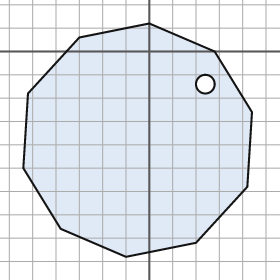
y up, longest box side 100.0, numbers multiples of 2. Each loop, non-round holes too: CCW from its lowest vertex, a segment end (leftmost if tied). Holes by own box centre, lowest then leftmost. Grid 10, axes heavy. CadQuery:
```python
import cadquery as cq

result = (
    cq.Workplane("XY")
    .moveTo(-10.0, -88.0)
    .lineTo(20.0, -82.0)
    .lineTo(42.0, -58.0)
    .lineTo(44.0, -26.0)
    .lineTo(28.0, 0.0)
    .lineTo(0.0, 12.0)
    .lineTo(-30.0, 6.0)
    .lineTo(-52.0, -18.0)
    .lineTo(-54.0, -50.0)
    .lineTo(-38.0, -76.0)
    .close()
    .moveTo(24.0, -14.0)
    .circle(4.0)
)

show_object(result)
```